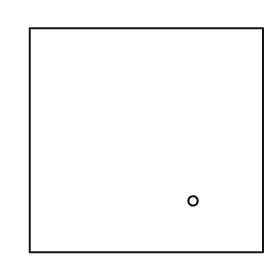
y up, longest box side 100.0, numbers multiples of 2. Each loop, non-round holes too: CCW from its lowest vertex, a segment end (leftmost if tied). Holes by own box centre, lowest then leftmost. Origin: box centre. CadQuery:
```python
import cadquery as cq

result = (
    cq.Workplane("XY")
    .moveTo(-50.0, -48.0)
    .lineTo(50.0, -48.0)
    .lineTo(50.0, 48.0)
    .lineTo(-50.0, 48.0)
    .close()
    .moveTo(20.0, -26.0)
    .circle(2.0)
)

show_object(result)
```